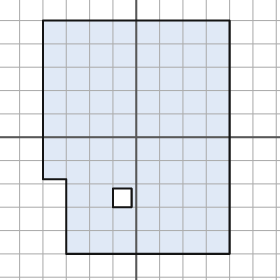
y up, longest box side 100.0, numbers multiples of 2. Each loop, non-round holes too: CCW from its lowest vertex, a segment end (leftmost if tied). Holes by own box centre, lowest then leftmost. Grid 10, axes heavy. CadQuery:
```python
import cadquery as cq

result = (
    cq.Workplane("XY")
    .moveTo(-30.0, -50.0)
    .lineTo(40.0, -50.0)
    .lineTo(40.0, 50.0)
    .lineTo(-40.0, 50.0)
    .lineTo(-40.0, -18.0)
    .lineTo(-30.0, -18.0)
    .close()
    .moveTo(-10.0, -30.0)
    .lineTo(-2.0, -30.0)
    .lineTo(-2.0, -22.0)
    .lineTo(-10.0, -22.0)
    .close()
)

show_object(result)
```